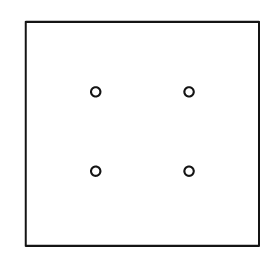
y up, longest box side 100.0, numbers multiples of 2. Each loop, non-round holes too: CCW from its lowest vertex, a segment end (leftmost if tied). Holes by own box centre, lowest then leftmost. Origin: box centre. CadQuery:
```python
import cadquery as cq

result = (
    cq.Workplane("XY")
    .moveTo(-50.0, -48.0)
    .lineTo(50.0, -48.0)
    .lineTo(50.0, 48.0)
    .lineTo(-50.0, 48.0)
    .close()
    .moveTo(-20.0, -16.0)
    .circle(2.0)
    .moveTo(20.0, -16.0)
    .circle(2.0)
    .moveTo(-20.0, 18.0)
    .circle(2.0)
    .moveTo(20.0, 18.0)
    .circle(2.0)
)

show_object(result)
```